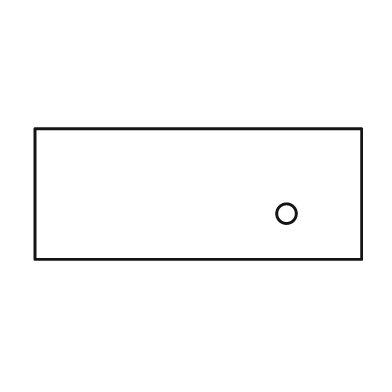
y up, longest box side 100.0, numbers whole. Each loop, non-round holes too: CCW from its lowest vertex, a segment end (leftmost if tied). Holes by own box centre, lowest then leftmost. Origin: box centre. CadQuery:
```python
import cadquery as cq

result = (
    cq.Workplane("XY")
    .moveTo(-50.0, -20.0)
    .lineTo(50.0, -20.0)
    .lineTo(50.0, 20.0)
    .lineTo(-50.0, 20.0)
    .close()
    .moveTo(27.0, -6.0)
    .circle(3.0)
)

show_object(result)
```